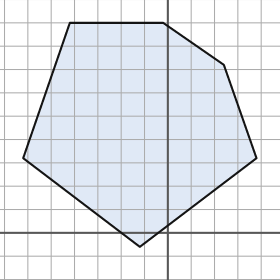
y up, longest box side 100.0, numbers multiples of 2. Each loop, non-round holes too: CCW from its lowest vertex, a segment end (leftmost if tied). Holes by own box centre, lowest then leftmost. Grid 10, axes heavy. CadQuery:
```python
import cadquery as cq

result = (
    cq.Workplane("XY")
    .moveTo(-12.0, -6.0)
    .lineTo(38.0, 32.0)
    .lineTo(24.0, 72.0)
    .lineTo(-2.0, 90.0)
    .lineTo(-42.0, 90.0)
    .lineTo(-62.0, 32.0)
    .close()
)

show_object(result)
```